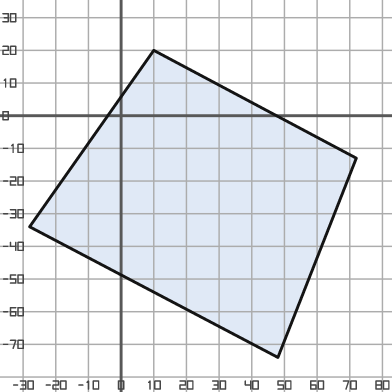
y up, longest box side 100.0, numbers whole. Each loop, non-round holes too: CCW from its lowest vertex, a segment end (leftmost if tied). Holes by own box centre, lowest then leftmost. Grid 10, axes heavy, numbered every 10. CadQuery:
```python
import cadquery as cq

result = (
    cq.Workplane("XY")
    .moveTo(48.0, -74.0)
    .lineTo(72.0, -13.0)
    .lineTo(10.0, 20.0)
    .lineTo(-28.0, -34.0)
    .close()
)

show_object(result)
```